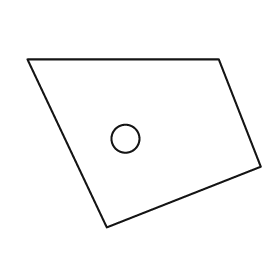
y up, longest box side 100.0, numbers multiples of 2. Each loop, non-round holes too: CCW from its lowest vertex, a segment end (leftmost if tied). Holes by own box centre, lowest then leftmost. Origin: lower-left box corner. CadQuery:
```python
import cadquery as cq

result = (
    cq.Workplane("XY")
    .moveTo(34.0, 0.0)
    .lineTo(100.0, 26.0)
    .lineTo(82.0, 72.0)
    .lineTo(0.0, 72.0)
    .close()
    .moveTo(42.0, 38.0)
    .circle(6.0)
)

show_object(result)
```